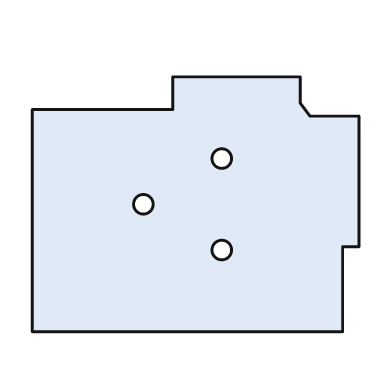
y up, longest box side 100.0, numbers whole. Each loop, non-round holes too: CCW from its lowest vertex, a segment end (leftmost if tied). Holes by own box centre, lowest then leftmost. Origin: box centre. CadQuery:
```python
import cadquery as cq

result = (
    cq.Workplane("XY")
    .moveTo(-50.0, -39.0)
    .lineTo(45.0, -39.0)
    .lineTo(45.0, -13.0)
    .lineTo(50.0, -13.0)
    .lineTo(50.0, 27.0)
    .lineTo(35.0, 27.0)
    .lineTo(32.0, 31.0)
    .lineTo(32.0, 39.0)
    .lineTo(-7.0, 39.0)
    .lineTo(-7.0, 29.0)
    .lineTo(-50.0, 29.0)
    .close()
    .moveTo(8.0, -14.0)
    .circle(3.0)
    .moveTo(-16.0, 0.0)
    .circle(3.0)
    .moveTo(8.0, 14.0)
    .circle(3.0)
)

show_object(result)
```